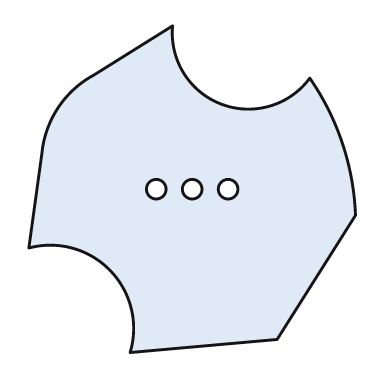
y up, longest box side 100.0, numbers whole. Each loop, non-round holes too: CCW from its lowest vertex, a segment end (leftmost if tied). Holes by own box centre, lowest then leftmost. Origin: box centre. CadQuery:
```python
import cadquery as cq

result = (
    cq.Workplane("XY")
    .moveTo(-19.0, -50.0)
    .lineTo(26.0, -46.0)
    .lineTo(50.0, -8.0)
    .threePointArc((46.0, 14.0), (36.0, 34.0))
    .threePointArc((9.0, 26.0), (-6.0, 50.0))
    .lineTo(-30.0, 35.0)
    .threePointArc((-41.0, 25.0), (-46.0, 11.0))
    .lineTo(-50.0, -18.0)
    .threePointArc((-25.0, -25.0), (-19.0, -50.0))
    .close()
    .moveTo(-11.0, 0.0)
    .circle(3.0)
    .moveTo(0.0, 0.0)
    .circle(3.0)
    .moveTo(11.0, 0.0)
    .circle(3.0)
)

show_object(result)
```